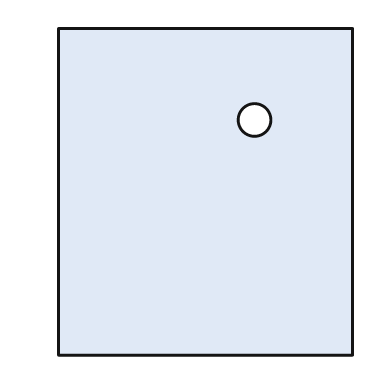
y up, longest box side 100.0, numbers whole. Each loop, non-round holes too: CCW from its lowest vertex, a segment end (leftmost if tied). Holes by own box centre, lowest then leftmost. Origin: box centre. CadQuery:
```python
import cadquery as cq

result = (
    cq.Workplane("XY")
    .moveTo(-45.0, -50.0)
    .lineTo(45.0, -50.0)
    .lineTo(45.0, 50.0)
    .lineTo(-45.0, 50.0)
    .close()
    .moveTo(15.0, 22.0)
    .circle(5.0)
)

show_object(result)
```